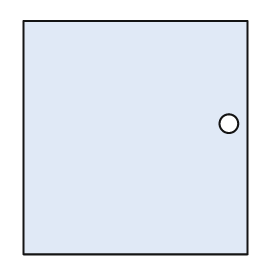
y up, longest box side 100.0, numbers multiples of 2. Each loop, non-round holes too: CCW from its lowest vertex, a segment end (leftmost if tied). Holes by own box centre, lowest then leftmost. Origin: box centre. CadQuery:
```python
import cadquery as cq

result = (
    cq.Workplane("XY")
    .moveTo(-48.0, -50.0)
    .lineTo(48.0, -50.0)
    .lineTo(48.0, 50.0)
    .lineTo(-48.0, 50.0)
    .close()
    .moveTo(40.0, 6.0)
    .circle(4.0)
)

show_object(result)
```